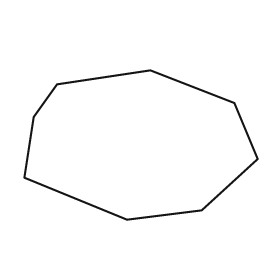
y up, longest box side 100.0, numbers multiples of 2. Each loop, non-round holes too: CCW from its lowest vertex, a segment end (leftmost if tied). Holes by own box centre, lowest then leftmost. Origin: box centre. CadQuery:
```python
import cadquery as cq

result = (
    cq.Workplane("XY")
    .moveTo(-6.0, -32.0)
    .lineTo(26.0, -28.0)
    .lineTo(50.0, -6.0)
    .lineTo(40.0, 18.0)
    .lineTo(4.0, 32.0)
    .lineTo(-36.0, 26.0)
    .lineTo(-46.0, 12.0)
    .lineTo(-50.0, -14.0)
    .close()
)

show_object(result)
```